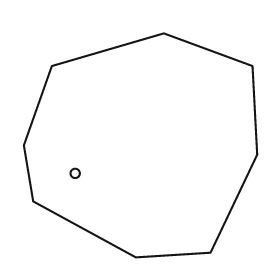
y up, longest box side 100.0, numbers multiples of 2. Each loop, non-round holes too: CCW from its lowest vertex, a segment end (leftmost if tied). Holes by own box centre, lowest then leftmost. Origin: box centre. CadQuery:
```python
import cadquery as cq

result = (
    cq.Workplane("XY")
    .moveTo(-2.0, -48.0)
    .lineTo(30.0, -46.0)
    .lineTo(50.0, -4.0)
    .lineTo(48.0, 34.0)
    .lineTo(10.0, 48.0)
    .lineTo(-38.0, 34.0)
    .lineTo(-50.0, 0.0)
    .lineTo(-46.0, -24.0)
    .close()
    .moveTo(-28.0, -12.0)
    .circle(2.0)
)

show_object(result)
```